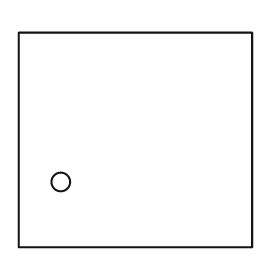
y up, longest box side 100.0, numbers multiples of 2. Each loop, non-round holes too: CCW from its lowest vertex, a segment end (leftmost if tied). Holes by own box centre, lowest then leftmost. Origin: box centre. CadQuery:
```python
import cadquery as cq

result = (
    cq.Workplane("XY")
    .moveTo(-50.0, -46.0)
    .lineTo(50.0, -46.0)
    .lineTo(50.0, 46.0)
    .lineTo(-50.0, 46.0)
    .close()
    .moveTo(-32.0, -18.0)
    .circle(4.0)
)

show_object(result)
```